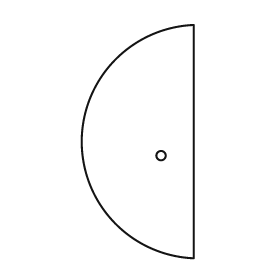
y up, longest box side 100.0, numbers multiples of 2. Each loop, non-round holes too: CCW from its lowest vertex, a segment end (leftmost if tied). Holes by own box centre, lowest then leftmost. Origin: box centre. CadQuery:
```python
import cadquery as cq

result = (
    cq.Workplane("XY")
    .moveTo(24.0, -50.0)
    .lineTo(24.0, 50.0)
    .threePointArc((-24.0, 0.0), (24.0, -50.0))
    .close()
    .moveTo(10.0, -6.0)
    .circle(2.0)
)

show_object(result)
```